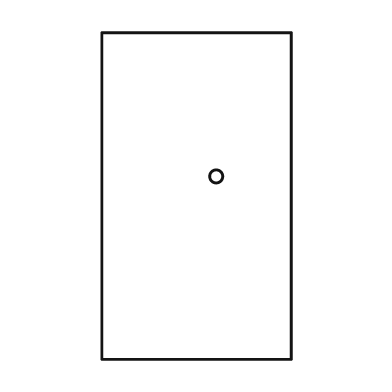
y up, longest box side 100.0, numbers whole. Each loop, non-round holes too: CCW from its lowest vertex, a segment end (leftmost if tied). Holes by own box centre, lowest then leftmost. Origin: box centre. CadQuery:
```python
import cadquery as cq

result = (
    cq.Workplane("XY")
    .moveTo(-29.0, -50.0)
    .lineTo(29.0, -50.0)
    .lineTo(29.0, 50.0)
    .lineTo(-29.0, 50.0)
    .close()
    .moveTo(6.0, 6.0)
    .circle(2.0)
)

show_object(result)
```